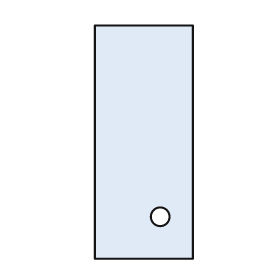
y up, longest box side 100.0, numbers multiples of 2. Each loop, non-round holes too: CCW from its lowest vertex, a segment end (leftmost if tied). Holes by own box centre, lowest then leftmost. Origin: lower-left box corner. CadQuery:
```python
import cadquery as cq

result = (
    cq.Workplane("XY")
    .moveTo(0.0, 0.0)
    .lineTo(42.0, 0.0)
    .lineTo(42.0, 100.0)
    .lineTo(0.0, 100.0)
    .close()
    .moveTo(28.0, 18.0)
    .circle(4.0)
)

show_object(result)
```